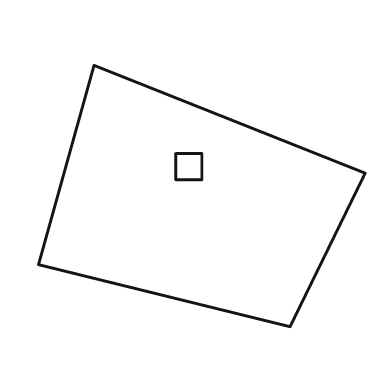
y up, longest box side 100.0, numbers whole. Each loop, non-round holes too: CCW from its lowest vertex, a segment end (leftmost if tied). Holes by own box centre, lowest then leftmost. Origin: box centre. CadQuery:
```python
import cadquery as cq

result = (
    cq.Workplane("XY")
    .moveTo(27.0, -40.0)
    .lineTo(50.0, 7.0)
    .lineTo(-33.0, 40.0)
    .lineTo(-50.0, -21.0)
    .close()
    .moveTo(-8.0, 5.0)
    .lineTo(0.0, 5.0)
    .lineTo(0.0, 13.0)
    .lineTo(-8.0, 13.0)
    .close()
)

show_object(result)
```